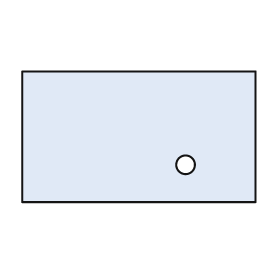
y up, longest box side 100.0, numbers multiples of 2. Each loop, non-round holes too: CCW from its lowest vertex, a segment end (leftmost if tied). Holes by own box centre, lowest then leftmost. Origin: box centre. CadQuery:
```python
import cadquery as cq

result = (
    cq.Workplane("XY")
    .moveTo(-50.0, -28.0)
    .lineTo(50.0, -28.0)
    .lineTo(50.0, 28.0)
    .lineTo(-50.0, 28.0)
    .close()
    .moveTo(20.0, -12.0)
    .circle(4.0)
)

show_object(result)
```